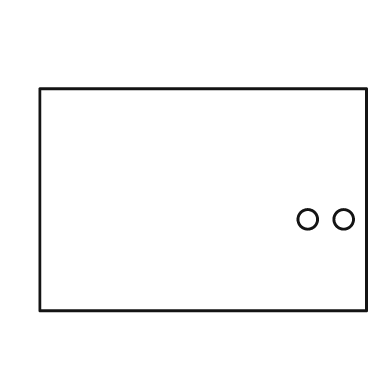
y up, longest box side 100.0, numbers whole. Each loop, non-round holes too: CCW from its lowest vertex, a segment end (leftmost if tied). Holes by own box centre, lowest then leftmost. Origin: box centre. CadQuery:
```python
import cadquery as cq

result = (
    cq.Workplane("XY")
    .moveTo(-50.0, -34.0)
    .lineTo(50.0, -34.0)
    .lineTo(50.0, 34.0)
    .lineTo(-50.0, 34.0)
    .close()
    .moveTo(32.0, -6.0)
    .circle(3.0)
    .moveTo(43.0, -6.0)
    .circle(3.0)
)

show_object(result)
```